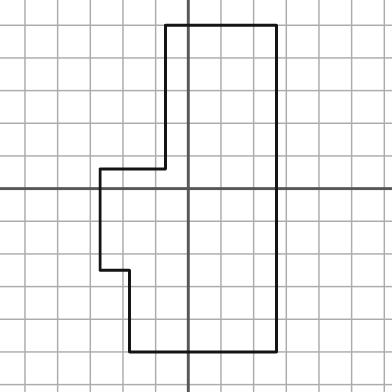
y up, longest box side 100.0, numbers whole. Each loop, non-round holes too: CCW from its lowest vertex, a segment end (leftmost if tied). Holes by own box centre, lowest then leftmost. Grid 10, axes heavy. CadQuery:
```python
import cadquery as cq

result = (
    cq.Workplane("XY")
    .moveTo(-18.0, -50.0)
    .lineTo(27.0, -50.0)
    .lineTo(27.0, 50.0)
    .lineTo(-7.0, 50.0)
    .lineTo(-7.0, 6.0)
    .lineTo(-27.0, 6.0)
    .lineTo(-27.0, -25.0)
    .lineTo(-18.0, -25.0)
    .close()
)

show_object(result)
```